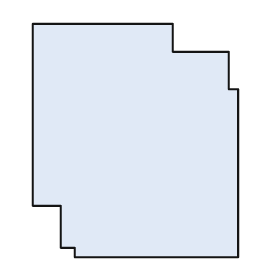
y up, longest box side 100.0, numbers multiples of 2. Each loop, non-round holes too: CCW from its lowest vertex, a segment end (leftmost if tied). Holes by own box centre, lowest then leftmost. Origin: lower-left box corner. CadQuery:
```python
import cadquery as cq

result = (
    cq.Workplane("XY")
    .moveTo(18.0, 0.0)
    .lineTo(88.0, 0.0)
    .lineTo(88.0, 72.0)
    .lineTo(84.0, 72.0)
    .lineTo(84.0, 88.0)
    .lineTo(60.0, 88.0)
    .lineTo(60.0, 100.0)
    .lineTo(0.0, 100.0)
    .lineTo(0.0, 22.0)
    .lineTo(12.0, 22.0)
    .lineTo(12.0, 4.0)
    .lineTo(18.0, 4.0)
    .close()
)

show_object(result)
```